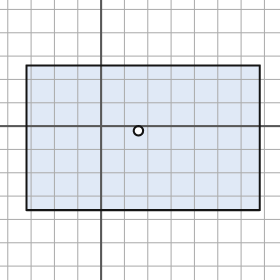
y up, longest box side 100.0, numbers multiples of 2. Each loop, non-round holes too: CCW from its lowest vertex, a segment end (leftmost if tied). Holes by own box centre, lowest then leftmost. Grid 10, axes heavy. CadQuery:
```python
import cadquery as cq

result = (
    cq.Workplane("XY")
    .moveTo(-32.0, -36.0)
    .lineTo(68.0, -36.0)
    .lineTo(68.0, 26.0)
    .lineTo(-32.0, 26.0)
    .close()
    .moveTo(16.0, -2.0)
    .circle(2.0)
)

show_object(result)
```